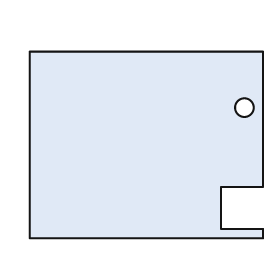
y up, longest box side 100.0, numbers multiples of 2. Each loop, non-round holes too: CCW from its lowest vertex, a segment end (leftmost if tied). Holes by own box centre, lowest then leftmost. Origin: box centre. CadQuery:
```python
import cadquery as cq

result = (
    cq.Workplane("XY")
    .moveTo(-50.0, -40.0)
    .lineTo(50.0, -40.0)
    .lineTo(50.0, -36.0)
    .lineTo(32.0, -36.0)
    .lineTo(32.0, -18.0)
    .lineTo(50.0, -18.0)
    .lineTo(50.0, 40.0)
    .lineTo(-50.0, 40.0)
    .close()
    .moveTo(42.0, 16.0)
    .circle(4.0)
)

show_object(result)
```